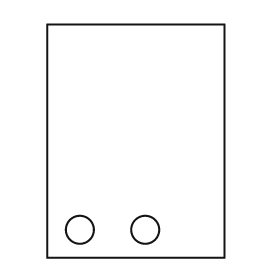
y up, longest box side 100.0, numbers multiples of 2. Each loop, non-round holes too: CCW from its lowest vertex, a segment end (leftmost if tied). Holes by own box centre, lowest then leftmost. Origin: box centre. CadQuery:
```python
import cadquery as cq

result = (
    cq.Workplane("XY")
    .moveTo(-38.0, -50.0)
    .lineTo(38.0, -50.0)
    .lineTo(38.0, 50.0)
    .lineTo(-38.0, 50.0)
    .close()
    .moveTo(-24.0, -38.0)
    .circle(6.0)
    .moveTo(4.0, -38.0)
    .circle(6.0)
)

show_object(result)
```